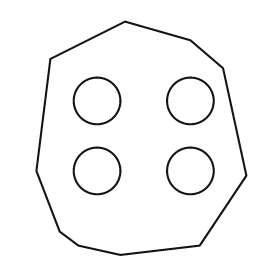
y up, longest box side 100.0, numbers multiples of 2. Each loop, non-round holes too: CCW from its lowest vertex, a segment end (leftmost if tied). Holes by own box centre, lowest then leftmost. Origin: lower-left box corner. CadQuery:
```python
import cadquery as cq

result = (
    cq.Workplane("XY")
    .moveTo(36.0, 0.0)
    .lineTo(70.0, 4.0)
    .lineTo(90.0, 34.0)
    .lineTo(80.0, 80.0)
    .lineTo(66.0, 92.0)
    .lineTo(38.0, 100.0)
    .lineTo(6.0, 84.0)
    .lineTo(0.0, 36.0)
    .lineTo(10.0, 10.0)
    .lineTo(18.0, 4.0)
    .close()
    .moveTo(26.0, 36.0)
    .circle(10.0)
    .moveTo(66.0, 36.0)
    .circle(10.0)
    .moveTo(26.0, 66.0)
    .circle(10.0)
    .moveTo(66.0, 66.0)
    .circle(10.0)
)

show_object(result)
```